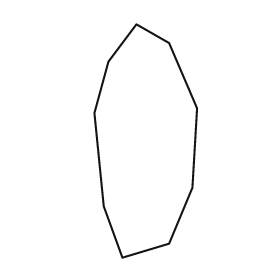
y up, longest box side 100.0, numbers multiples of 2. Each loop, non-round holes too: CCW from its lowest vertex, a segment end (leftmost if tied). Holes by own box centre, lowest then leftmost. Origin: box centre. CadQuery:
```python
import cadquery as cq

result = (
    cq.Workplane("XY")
    .moveTo(-10.0, -50.0)
    .lineTo(10.0, -44.0)
    .lineTo(20.0, -20.0)
    .lineTo(22.0, 14.0)
    .lineTo(10.0, 42.0)
    .lineTo(-4.0, 50.0)
    .lineTo(-16.0, 34.0)
    .lineTo(-22.0, 12.0)
    .lineTo(-18.0, -28.0)
    .close()
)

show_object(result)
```